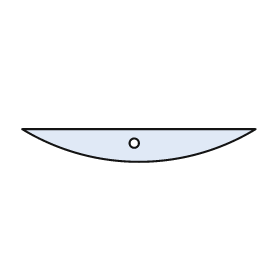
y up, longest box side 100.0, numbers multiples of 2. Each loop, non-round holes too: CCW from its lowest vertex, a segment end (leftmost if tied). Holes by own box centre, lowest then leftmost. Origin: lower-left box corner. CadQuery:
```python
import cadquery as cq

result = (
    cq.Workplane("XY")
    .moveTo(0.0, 14.0)
    .threePointArc((50.0, 0.0), (100.0, 14.0))
    .close()
    .moveTo(48.0, 8.0)
    .circle(2.0)
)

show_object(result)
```